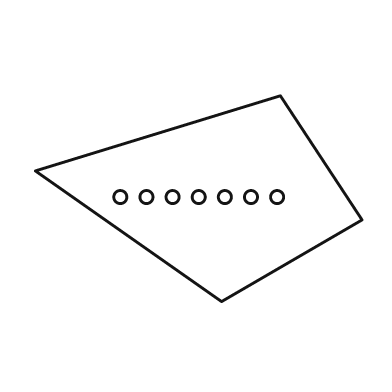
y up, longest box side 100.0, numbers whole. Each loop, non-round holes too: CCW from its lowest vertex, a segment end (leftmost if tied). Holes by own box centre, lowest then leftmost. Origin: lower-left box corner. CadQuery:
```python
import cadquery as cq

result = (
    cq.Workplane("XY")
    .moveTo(57.0, 0.0)
    .lineTo(100.0, 25.0)
    .lineTo(75.0, 63.0)
    .lineTo(0.0, 40.0)
    .close()
    .moveTo(26.0, 32.0)
    .circle(2.0)
    .moveTo(34.0, 32.0)
    .circle(2.0)
    .moveTo(42.0, 32.0)
    .circle(2.0)
    .moveTo(50.0, 32.0)
    .circle(2.0)
    .moveTo(58.0, 32.0)
    .circle(2.0)
    .moveTo(66.0, 32.0)
    .circle(2.0)
    .moveTo(74.0, 32.0)
    .circle(2.0)
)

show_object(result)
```